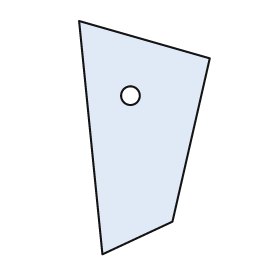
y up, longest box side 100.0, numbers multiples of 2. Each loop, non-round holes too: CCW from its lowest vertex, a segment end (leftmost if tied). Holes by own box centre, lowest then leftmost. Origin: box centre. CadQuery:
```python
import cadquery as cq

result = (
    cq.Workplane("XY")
    .moveTo(-18.0, -50.0)
    .lineTo(12.0, -36.0)
    .lineTo(28.0, 34.0)
    .lineTo(-28.0, 50.0)
    .close()
    .moveTo(-6.0, 18.0)
    .circle(4.0)
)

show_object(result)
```